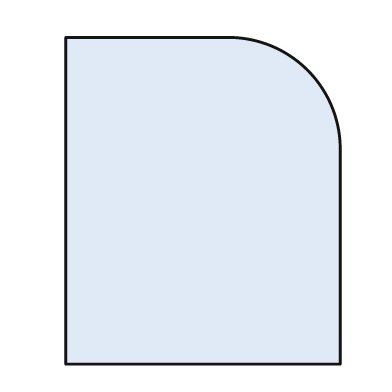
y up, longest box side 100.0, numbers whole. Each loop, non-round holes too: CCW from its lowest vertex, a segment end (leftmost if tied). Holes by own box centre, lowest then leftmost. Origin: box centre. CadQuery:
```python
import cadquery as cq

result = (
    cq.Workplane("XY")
    .moveTo(-42.0, -50.0)
    .lineTo(42.0, -50.0)
    .lineTo(42.0, 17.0)
    .threePointArc((32.0, 40.0), (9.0, 50.0))
    .lineTo(-42.0, 50.0)
    .close()
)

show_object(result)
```